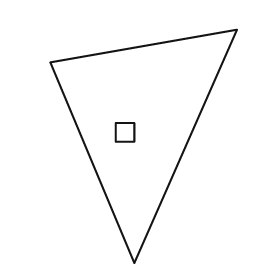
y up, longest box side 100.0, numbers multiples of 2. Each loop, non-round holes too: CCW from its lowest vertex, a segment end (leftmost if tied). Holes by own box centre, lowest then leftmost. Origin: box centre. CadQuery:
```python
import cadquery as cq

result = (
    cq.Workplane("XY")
    .moveTo(-4.0, -50.0)
    .lineTo(40.0, 50.0)
    .lineTo(-40.0, 36.0)
    .close()
    .moveTo(-12.0, 2.0)
    .lineTo(-4.0, 2.0)
    .lineTo(-4.0, 10.0)
    .lineTo(-12.0, 10.0)
    .close()
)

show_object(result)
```